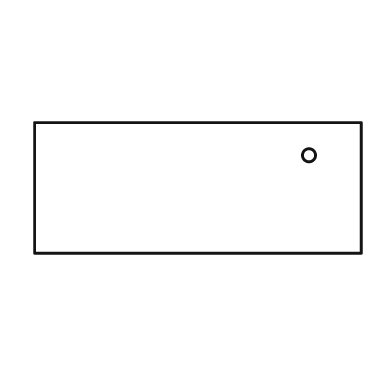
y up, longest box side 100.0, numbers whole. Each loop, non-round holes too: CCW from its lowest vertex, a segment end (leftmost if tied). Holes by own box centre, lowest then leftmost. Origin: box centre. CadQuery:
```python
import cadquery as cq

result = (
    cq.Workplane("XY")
    .moveTo(-50.0, -20.0)
    .lineTo(50.0, -20.0)
    .lineTo(50.0, 20.0)
    .lineTo(-50.0, 20.0)
    .close()
    .moveTo(34.0, 10.0)
    .circle(2.0)
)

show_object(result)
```